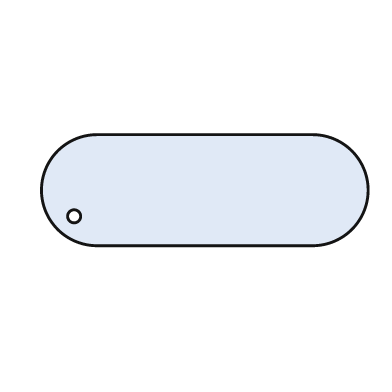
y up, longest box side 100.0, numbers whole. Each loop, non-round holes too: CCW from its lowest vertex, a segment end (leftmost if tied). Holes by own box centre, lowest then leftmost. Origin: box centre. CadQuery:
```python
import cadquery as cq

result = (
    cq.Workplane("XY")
    .moveTo(-33.0, -17.0)
    .lineTo(33.0, -17.0)
    .threePointArc((50.0, 0.0), (33.0, 17.0))
    .lineTo(-33.0, 17.0)
    .threePointArc((-50.0, 0.0), (-33.0, -17.0))
    .close()
    .moveTo(-40.0, -8.0)
    .circle(2.0)
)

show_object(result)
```